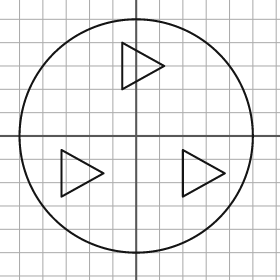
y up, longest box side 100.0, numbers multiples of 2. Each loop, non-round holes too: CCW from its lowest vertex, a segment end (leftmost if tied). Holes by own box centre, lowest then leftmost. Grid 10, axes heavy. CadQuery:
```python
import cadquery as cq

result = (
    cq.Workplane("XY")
    .moveTo(0.0, 0.0)
    .circle(50.0)
    .moveTo(-32.0, -26.0)
    .lineTo(-14.0, -16.0)
    .lineTo(-32.0, -6.0)
    .close()
    .moveTo(20.0, -26.0)
    .lineTo(38.0, -16.0)
    .lineTo(20.0, -6.0)
    .close()
    .moveTo(-6.0, 20.0)
    .lineTo(12.0, 30.0)
    .lineTo(-6.0, 40.0)
    .close()
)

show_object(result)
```